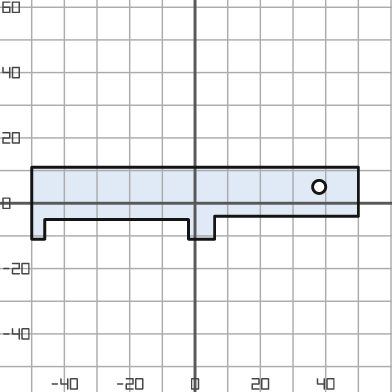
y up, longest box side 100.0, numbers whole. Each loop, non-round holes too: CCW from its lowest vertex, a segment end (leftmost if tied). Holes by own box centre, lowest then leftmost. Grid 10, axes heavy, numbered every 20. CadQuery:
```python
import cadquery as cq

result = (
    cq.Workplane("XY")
    .moveTo(-50.0, -11.0)
    .lineTo(-46.0, -11.0)
    .lineTo(-46.0, -5.0)
    .lineTo(-2.0, -5.0)
    .lineTo(-2.0, -11.0)
    .lineTo(6.0, -11.0)
    .lineTo(6.0, -4.0)
    .lineTo(50.0, -4.0)
    .lineTo(50.0, 11.0)
    .lineTo(-50.0, 11.0)
    .close()
    .moveTo(38.0, 5.0)
    .circle(2.0)
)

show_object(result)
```